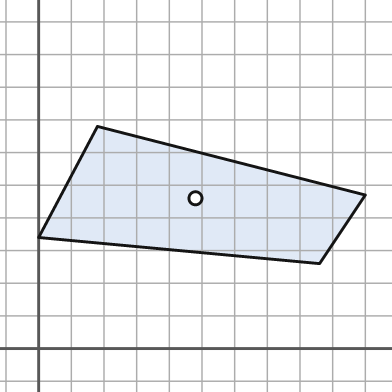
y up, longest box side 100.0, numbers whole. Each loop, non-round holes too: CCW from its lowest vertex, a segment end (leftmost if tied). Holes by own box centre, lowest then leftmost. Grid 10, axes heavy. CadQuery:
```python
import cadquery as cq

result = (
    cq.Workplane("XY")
    .moveTo(86.0, 26.0)
    .lineTo(100.0, 47.0)
    .lineTo(18.0, 68.0)
    .lineTo(0.0, 34.0)
    .close()
    .moveTo(48.0, 46.0)
    .circle(2.0)
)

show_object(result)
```